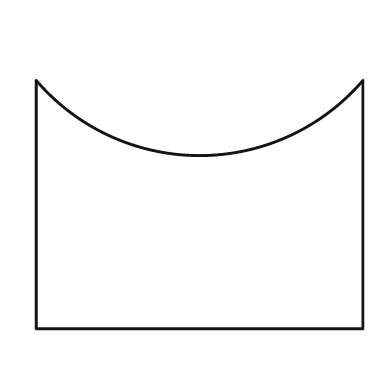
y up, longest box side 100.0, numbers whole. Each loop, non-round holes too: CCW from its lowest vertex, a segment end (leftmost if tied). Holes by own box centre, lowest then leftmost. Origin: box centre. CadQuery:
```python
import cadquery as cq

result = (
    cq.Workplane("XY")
    .moveTo(-50.0, -38.0)
    .lineTo(50.0, -38.0)
    .lineTo(50.0, 38.0)
    .threePointArc((0.0, 15.0), (-50.0, 38.0))
    .close()
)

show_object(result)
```